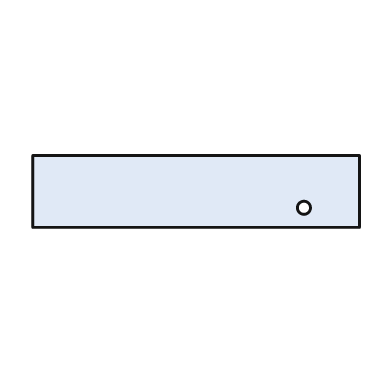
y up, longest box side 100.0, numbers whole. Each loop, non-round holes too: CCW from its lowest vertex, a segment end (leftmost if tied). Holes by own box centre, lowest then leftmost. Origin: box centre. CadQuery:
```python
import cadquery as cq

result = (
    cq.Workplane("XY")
    .moveTo(-50.0, -11.0)
    .lineTo(50.0, -11.0)
    .lineTo(50.0, 11.0)
    .lineTo(-50.0, 11.0)
    .close()
    .moveTo(33.0, -5.0)
    .circle(2.0)
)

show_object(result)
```